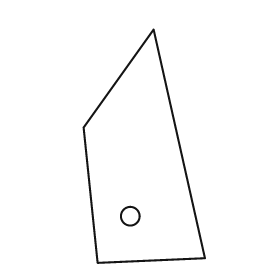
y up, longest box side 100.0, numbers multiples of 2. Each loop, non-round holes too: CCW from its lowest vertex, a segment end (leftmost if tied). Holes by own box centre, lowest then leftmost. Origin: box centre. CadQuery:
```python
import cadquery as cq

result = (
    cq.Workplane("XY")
    .moveTo(-20.0, -50.0)
    .lineTo(26.0, -48.0)
    .lineTo(4.0, 50.0)
    .lineTo(-26.0, 8.0)
    .close()
    .moveTo(-6.0, -30.0)
    .circle(4.0)
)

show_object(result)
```